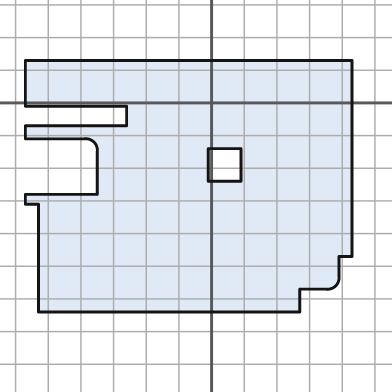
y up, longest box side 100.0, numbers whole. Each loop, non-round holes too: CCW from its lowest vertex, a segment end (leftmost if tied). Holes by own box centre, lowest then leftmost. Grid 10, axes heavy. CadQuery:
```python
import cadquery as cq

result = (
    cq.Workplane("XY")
    .moveTo(-53.0, -64.0)
    .lineTo(27.0, -64.0)
    .lineTo(27.0, -57.0)
    .lineTo(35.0, -57.0)
    .threePointArc((38.0, -56.0), (39.0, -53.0))
    .lineTo(39.0, -47.0)
    .lineTo(43.0, -47.0)
    .lineTo(43.0, 13.0)
    .lineTo(-57.0, 13.0)
    .lineTo(-57.0, -1.0)
    .lineTo(-26.0, -1.0)
    .lineTo(-26.0, -7.0)
    .lineTo(-57.0, -7.0)
    .lineTo(-57.0, -11.0)
    .lineTo(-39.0, -11.0)
    .threePointArc((-36.0, -12.0), (-35.0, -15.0))
    .lineTo(-35.0, -28.0)
    .lineTo(-57.0, -28.0)
    .lineTo(-57.0, -31.0)
    .lineTo(-53.0, -31.0)
    .close()
    .moveTo(-1.0, -24.0)
    .lineTo(9.0, -24.0)
    .lineTo(9.0, -14.0)
    .lineTo(-1.0, -14.0)
    .close()
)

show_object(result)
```